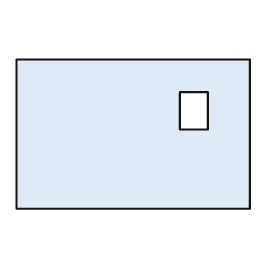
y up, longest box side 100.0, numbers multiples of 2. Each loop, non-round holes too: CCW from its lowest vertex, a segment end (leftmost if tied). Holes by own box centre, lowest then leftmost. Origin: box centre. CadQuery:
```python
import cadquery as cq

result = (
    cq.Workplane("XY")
    .moveTo(-50.0, -32.0)
    .lineTo(50.0, -32.0)
    .lineTo(50.0, 32.0)
    .lineTo(-50.0, 32.0)
    .close()
    .moveTo(20.0, 2.0)
    .lineTo(32.0, 2.0)
    .lineTo(32.0, 18.0)
    .lineTo(20.0, 18.0)
    .close()
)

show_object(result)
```